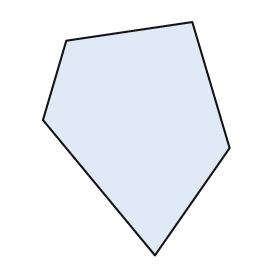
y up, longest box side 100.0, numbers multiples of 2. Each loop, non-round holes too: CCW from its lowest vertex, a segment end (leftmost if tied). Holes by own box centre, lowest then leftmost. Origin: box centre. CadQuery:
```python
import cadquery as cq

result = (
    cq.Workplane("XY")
    .moveTo(8.0, -50.0)
    .lineTo(40.0, -4.0)
    .lineTo(24.0, 50.0)
    .lineTo(-30.0, 42.0)
    .lineTo(-40.0, 8.0)
    .close()
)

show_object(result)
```